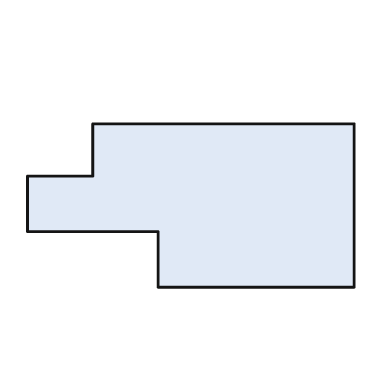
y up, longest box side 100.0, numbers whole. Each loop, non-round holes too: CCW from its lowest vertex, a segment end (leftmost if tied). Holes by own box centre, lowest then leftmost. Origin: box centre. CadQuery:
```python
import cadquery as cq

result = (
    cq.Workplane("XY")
    .moveTo(-10.0, -25.0)
    .lineTo(50.0, -25.0)
    .lineTo(50.0, 25.0)
    .lineTo(-30.0, 25.0)
    .lineTo(-30.0, 9.0)
    .lineTo(-50.0, 9.0)
    .lineTo(-50.0, -8.0)
    .lineTo(-10.0, -8.0)
    .close()
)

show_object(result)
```